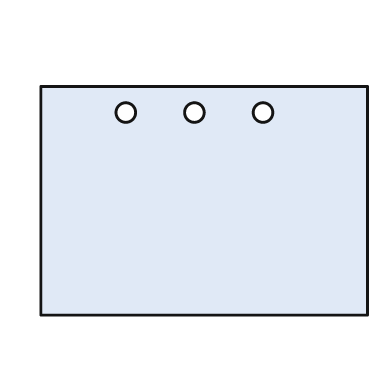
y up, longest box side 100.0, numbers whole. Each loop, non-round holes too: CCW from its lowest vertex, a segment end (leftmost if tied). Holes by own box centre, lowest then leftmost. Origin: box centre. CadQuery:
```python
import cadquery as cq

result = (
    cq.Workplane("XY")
    .moveTo(-50.0, -35.0)
    .lineTo(50.0, -35.0)
    .lineTo(50.0, 35.0)
    .lineTo(-50.0, 35.0)
    .close()
    .moveTo(-24.0, 27.0)
    .circle(3.0)
    .moveTo(-3.0, 27.0)
    .circle(3.0)
    .moveTo(18.0, 27.0)
    .circle(3.0)
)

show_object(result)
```